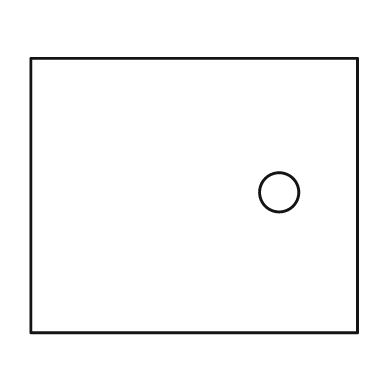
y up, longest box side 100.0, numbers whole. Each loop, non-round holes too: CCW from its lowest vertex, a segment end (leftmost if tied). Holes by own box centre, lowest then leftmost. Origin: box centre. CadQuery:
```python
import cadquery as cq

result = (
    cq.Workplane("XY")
    .moveTo(-50.0, -42.0)
    .lineTo(50.0, -42.0)
    .lineTo(50.0, 42.0)
    .lineTo(-50.0, 42.0)
    .close()
    .moveTo(26.0, 1.0)
    .circle(6.0)
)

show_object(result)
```